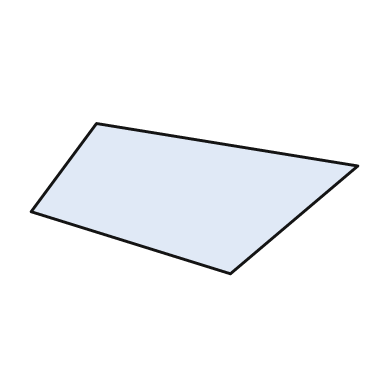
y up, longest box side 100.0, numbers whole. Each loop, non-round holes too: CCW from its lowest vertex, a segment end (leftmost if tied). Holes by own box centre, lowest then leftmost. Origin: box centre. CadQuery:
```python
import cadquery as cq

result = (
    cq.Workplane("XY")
    .moveTo(11.0, -23.0)
    .lineTo(50.0, 10.0)
    .lineTo(-30.0, 23.0)
    .lineTo(-50.0, -4.0)
    .close()
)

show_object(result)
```